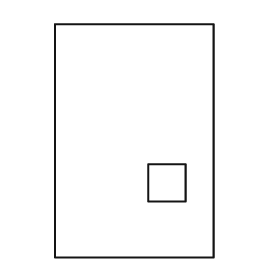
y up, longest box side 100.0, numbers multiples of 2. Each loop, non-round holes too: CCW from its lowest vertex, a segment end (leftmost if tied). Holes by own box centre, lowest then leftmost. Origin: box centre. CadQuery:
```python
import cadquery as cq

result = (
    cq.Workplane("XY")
    .moveTo(-34.0, -50.0)
    .lineTo(34.0, -50.0)
    .lineTo(34.0, 50.0)
    .lineTo(-34.0, 50.0)
    .close()
    .moveTo(6.0, -26.0)
    .lineTo(22.0, -26.0)
    .lineTo(22.0, -10.0)
    .lineTo(6.0, -10.0)
    .close()
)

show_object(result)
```